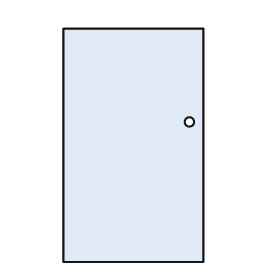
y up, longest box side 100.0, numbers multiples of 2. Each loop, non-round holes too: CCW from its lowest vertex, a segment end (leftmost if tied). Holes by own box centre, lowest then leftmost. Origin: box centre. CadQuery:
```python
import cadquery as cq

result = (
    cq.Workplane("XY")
    .moveTo(-30.0, -50.0)
    .lineTo(30.0, -50.0)
    .lineTo(30.0, 50.0)
    .lineTo(-30.0, 50.0)
    .close()
    .moveTo(24.0, 10.0)
    .circle(2.0)
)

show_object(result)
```